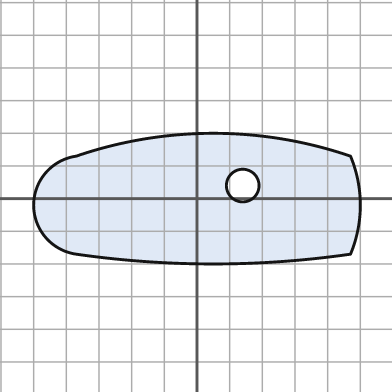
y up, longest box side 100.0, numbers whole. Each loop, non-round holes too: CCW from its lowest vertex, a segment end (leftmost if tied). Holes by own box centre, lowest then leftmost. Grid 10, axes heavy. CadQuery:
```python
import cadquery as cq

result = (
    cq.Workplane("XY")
    .moveTo(-37.0, -17.0)
    .threePointArc((5.0, -20.0), (47.0, -17.0))
    .threePointArc((50.0, -2.0), (47.0, 13.0))
    .threePointArc((5.0, 20.0), (-37.0, 13.0))
    .threePointArc((-50.0, -2.0), (-37.0, -17.0))
    .close()
    .moveTo(14.0, 4.0)
    .circle(5.0)
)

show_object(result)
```